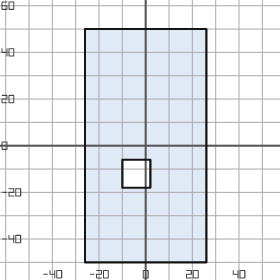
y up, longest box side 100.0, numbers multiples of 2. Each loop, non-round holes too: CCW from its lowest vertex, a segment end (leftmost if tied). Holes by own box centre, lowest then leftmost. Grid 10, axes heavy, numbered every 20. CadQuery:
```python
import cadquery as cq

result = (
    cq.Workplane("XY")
    .moveTo(-26.0, -50.0)
    .lineTo(26.0, -50.0)
    .lineTo(26.0, 50.0)
    .lineTo(-26.0, 50.0)
    .close()
    .moveTo(-10.0, -18.0)
    .lineTo(2.0, -18.0)
    .lineTo(2.0, -6.0)
    .lineTo(-10.0, -6.0)
    .close()
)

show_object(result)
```